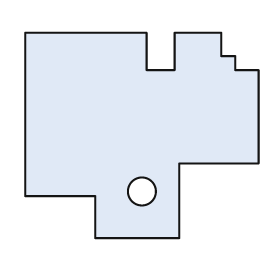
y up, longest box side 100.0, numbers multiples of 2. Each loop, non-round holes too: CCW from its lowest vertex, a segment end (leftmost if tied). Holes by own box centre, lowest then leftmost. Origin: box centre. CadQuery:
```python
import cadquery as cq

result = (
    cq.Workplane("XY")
    .moveTo(-20.0, -44.0)
    .lineTo(16.0, -44.0)
    .lineTo(16.0, -12.0)
    .lineTo(50.0, -12.0)
    .lineTo(50.0, 28.0)
    .lineTo(40.0, 28.0)
    .lineTo(40.0, 34.0)
    .lineTo(34.0, 34.0)
    .lineTo(34.0, 44.0)
    .lineTo(14.0, 44.0)
    .lineTo(14.0, 28.0)
    .lineTo(2.0, 28.0)
    .lineTo(2.0, 44.0)
    .lineTo(-50.0, 44.0)
    .lineTo(-50.0, -26.0)
    .lineTo(-20.0, -26.0)
    .close()
    .moveTo(0.0, -24.0)
    .circle(6.0)
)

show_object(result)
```